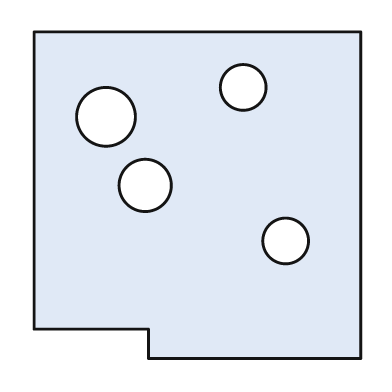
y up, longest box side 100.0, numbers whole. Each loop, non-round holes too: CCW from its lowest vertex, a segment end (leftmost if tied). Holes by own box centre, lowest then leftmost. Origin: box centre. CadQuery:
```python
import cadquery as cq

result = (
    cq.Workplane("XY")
    .moveTo(-15.0, -50.0)
    .lineTo(50.0, -50.0)
    .lineTo(50.0, 50.0)
    .lineTo(-50.0, 50.0)
    .lineTo(-50.0, -41.0)
    .lineTo(-15.0, -41.0)
    .close()
    .moveTo(27.0, -14.0)
    .circle(7.0)
    .moveTo(-16.0, 3.0)
    .circle(8.0)
    .moveTo(-28.0, 24.0)
    .circle(9.0)
    .moveTo(14.0, 33.0)
    .circle(7.0)
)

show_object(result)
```